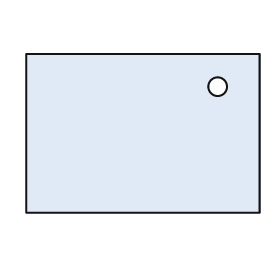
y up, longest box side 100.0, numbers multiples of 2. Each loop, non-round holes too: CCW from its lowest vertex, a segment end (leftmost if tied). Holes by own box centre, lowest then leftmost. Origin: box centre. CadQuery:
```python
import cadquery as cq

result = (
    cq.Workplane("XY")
    .moveTo(-50.0, -34.0)
    .lineTo(50.0, -34.0)
    .lineTo(50.0, 34.0)
    .lineTo(-50.0, 34.0)
    .close()
    .moveTo(32.0, 20.0)
    .circle(4.0)
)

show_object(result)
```